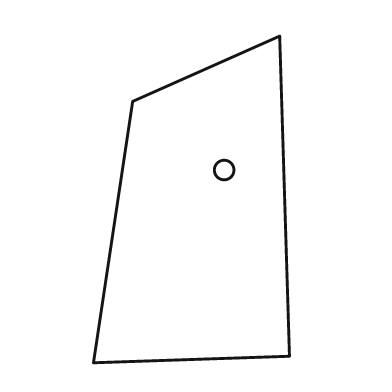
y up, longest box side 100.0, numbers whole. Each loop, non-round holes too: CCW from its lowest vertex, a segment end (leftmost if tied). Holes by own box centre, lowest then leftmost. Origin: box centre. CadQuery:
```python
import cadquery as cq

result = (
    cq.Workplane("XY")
    .moveTo(-30.0, -50.0)
    .lineTo(30.0, -48.0)
    .lineTo(27.0, 50.0)
    .lineTo(-18.0, 30.0)
    .close()
    .moveTo(10.0, 9.0)
    .circle(3.0)
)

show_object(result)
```